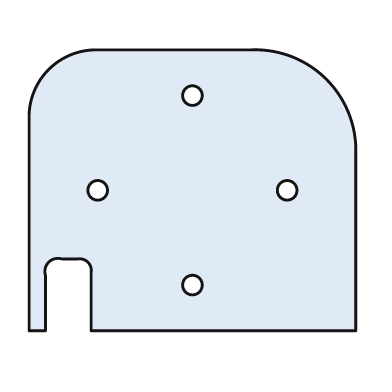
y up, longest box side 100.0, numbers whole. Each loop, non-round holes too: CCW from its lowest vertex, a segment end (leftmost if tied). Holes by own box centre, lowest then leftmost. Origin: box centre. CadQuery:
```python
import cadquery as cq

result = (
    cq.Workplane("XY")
    .moveTo(-50.0, -43.0)
    .lineTo(-45.0, -43.0)
    .lineTo(-45.0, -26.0)
    .threePointArc((-44.0, -22.0), (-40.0, -21.0))
    .lineTo(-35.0, -21.0)
    .threePointArc((-32.0, -22.0), (-31.0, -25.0))
    .lineTo(-31.0, -43.0)
    .lineTo(50.0, -43.0)
    .lineTo(50.0, 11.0)
    .threePointArc((41.0, 34.0), (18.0, 43.0))
    .lineTo(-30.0, 43.0)
    .threePointArc((-44.0, 37.0), (-50.0, 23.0))
    .close()
    .moveTo(0.0, -29.0)
    .circle(3.0)
    .moveTo(-29.0, 0.0)
    .circle(3.0)
    .moveTo(29.0, 0.0)
    .circle(3.0)
    .moveTo(0.0, 29.0)
    .circle(3.0)
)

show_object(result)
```